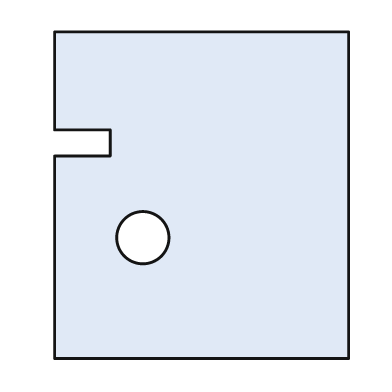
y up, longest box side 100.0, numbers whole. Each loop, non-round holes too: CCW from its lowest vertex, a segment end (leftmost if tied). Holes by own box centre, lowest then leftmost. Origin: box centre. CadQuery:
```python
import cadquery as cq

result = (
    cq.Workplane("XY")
    .moveTo(-45.0, -50.0)
    .lineTo(45.0, -50.0)
    .lineTo(45.0, 50.0)
    .lineTo(-45.0, 50.0)
    .lineTo(-45.0, 20.0)
    .lineTo(-28.0, 20.0)
    .lineTo(-28.0, 12.0)
    .lineTo(-45.0, 12.0)
    .close()
    .moveTo(-18.0, -13.0)
    .circle(8.0)
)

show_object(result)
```